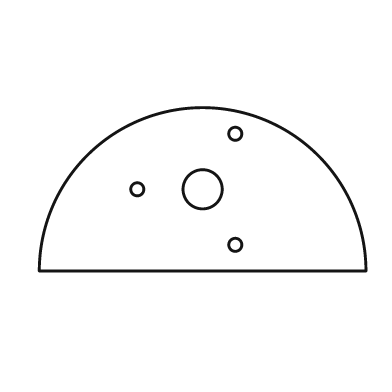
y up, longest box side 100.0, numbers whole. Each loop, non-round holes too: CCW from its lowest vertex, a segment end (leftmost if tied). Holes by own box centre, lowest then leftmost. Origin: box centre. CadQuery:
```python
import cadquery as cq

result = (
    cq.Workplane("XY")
    .moveTo(-50.0, -25.0)
    .lineTo(50.0, -25.0)
    .threePointArc((0.0, 25.0), (-50.0, -25.0))
    .close()
    .moveTo(10.0, -17.0)
    .circle(2.0)
    .moveTo(-20.0, 0.0)
    .circle(2.0)
    .moveTo(0.0, 0.0)
    .circle(6.0)
    .moveTo(10.0, 17.0)
    .circle(2.0)
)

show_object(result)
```